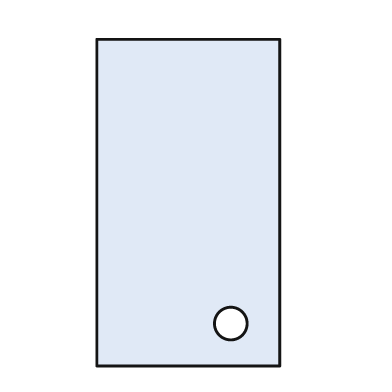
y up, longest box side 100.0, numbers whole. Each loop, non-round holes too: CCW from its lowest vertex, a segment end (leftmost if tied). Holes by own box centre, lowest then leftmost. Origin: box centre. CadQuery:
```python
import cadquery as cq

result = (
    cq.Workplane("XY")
    .moveTo(-28.0, -50.0)
    .lineTo(28.0, -50.0)
    .lineTo(28.0, 50.0)
    .lineTo(-28.0, 50.0)
    .close()
    .moveTo(13.0, -37.0)
    .circle(5.0)
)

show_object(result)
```